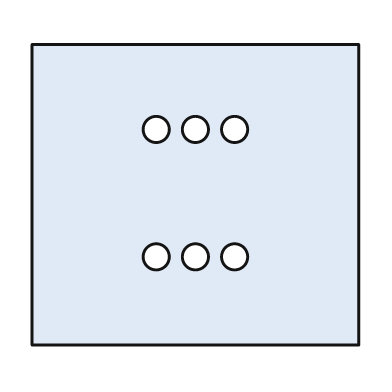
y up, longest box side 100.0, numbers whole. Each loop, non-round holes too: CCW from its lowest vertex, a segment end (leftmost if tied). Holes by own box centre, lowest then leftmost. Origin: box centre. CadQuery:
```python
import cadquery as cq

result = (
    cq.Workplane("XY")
    .moveTo(-50.0, -46.0)
    .lineTo(50.0, -46.0)
    .lineTo(50.0, 46.0)
    .lineTo(-50.0, 46.0)
    .close()
    .moveTo(-12.0, -19.0)
    .circle(4.0)
    .moveTo(0.0, -19.0)
    .circle(4.0)
    .moveTo(12.0, -19.0)
    .circle(4.0)
    .moveTo(-12.0, 20.0)
    .circle(4.0)
    .moveTo(0.0, 20.0)
    .circle(4.0)
    .moveTo(12.0, 20.0)
    .circle(4.0)
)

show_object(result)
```